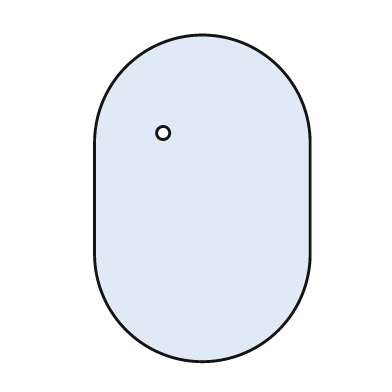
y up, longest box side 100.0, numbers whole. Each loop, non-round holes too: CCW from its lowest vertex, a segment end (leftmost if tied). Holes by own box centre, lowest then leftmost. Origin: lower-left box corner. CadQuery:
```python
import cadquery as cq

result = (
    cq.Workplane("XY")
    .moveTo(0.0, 33.0)
    .threePointArc((33.0, 0.0), (66.0, 33.0))
    .lineTo(66.0, 67.0)
    .threePointArc((33.0, 100.0), (0.0, 67.0))
    .close()
    .moveTo(21.0, 70.0)
    .circle(2.0)
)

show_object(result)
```